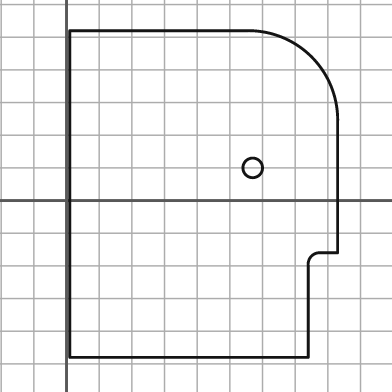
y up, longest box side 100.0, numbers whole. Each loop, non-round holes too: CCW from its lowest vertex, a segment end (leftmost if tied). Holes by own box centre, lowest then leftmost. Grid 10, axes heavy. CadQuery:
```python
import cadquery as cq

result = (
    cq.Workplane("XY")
    .moveTo(1.0, -48.0)
    .lineTo(74.0, -48.0)
    .lineTo(74.0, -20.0)
    .threePointArc((75.0, -17.0), (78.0, -16.0))
    .lineTo(83.0, -16.0)
    .lineTo(83.0, 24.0)
    .threePointArc((75.0, 44.0), (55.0, 52.0))
    .lineTo(1.0, 52.0)
    .close()
    .moveTo(57.0, 10.0)
    .circle(3.0)
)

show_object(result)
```